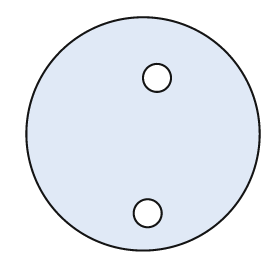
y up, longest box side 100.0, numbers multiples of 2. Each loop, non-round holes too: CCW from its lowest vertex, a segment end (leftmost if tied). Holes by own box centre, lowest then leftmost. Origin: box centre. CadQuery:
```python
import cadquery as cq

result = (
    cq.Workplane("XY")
    .moveTo(0.0, 0.0)
    .circle(50.0)
    .moveTo(2.0, -34.0)
    .circle(6.0)
    .moveTo(6.0, 24.0)
    .circle(6.0)
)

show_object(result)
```